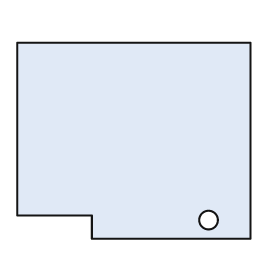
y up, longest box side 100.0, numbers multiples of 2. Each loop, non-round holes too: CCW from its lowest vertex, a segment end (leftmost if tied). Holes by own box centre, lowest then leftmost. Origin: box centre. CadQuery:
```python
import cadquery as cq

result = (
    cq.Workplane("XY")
    .moveTo(-18.0, -42.0)
    .lineTo(50.0, -42.0)
    .lineTo(50.0, 42.0)
    .lineTo(-50.0, 42.0)
    .lineTo(-50.0, -32.0)
    .lineTo(-18.0, -32.0)
    .close()
    .moveTo(32.0, -34.0)
    .circle(4.0)
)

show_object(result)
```